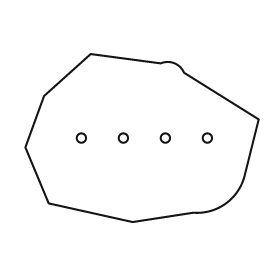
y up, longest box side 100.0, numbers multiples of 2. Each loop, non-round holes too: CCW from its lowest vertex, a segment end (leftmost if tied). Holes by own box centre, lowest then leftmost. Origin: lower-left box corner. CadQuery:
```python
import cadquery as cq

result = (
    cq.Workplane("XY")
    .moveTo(46.0, 0.0)
    .lineTo(72.0, 4.0)
    .threePointArc((86.0, 8.0), (94.0, 20.0))
    .lineTo(100.0, 44.0)
    .lineTo(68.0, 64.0)
    .threePointArc((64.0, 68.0), (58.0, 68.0))
    .lineTo(28.0, 72.0)
    .lineTo(8.0, 54.0)
    .lineTo(0.0, 32.0)
    .lineTo(10.0, 8.0)
    .close()
    .moveTo(24.0, 36.0)
    .circle(2.0)
    .moveTo(42.0, 36.0)
    .circle(2.0)
    .moveTo(60.0, 36.0)
    .circle(2.0)
    .moveTo(78.0, 36.0)
    .circle(2.0)
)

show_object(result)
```